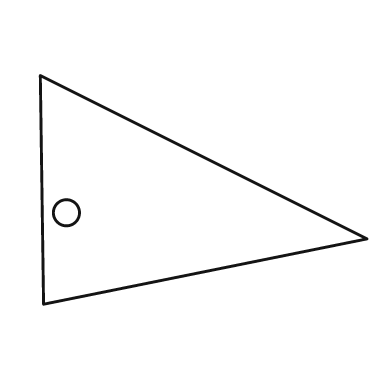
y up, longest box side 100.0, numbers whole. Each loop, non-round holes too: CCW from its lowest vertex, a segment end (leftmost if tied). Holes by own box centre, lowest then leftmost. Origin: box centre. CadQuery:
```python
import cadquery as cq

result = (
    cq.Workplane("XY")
    .moveTo(-49.0, -35.0)
    .lineTo(50.0, -15.0)
    .lineTo(-50.0, 35.0)
    .close()
    .moveTo(-42.0, -7.0)
    .circle(4.0)
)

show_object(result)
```